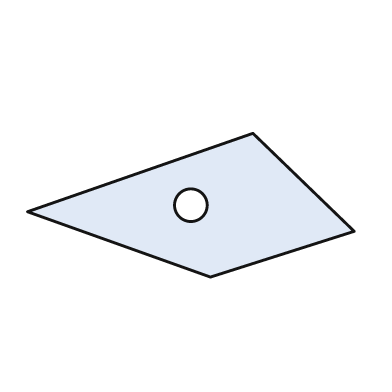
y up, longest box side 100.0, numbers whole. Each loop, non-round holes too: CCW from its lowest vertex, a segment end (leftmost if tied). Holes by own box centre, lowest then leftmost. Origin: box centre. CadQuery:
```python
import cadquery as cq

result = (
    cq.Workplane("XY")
    .moveTo(6.0, -22.0)
    .lineTo(50.0, -8.0)
    .lineTo(19.0, 22.0)
    .lineTo(-50.0, -2.0)
    .close()
    .moveTo(0.0, 0.0)
    .circle(5.0)
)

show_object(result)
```